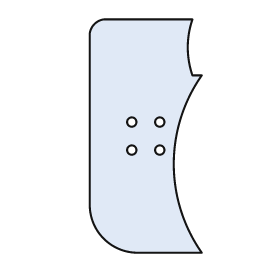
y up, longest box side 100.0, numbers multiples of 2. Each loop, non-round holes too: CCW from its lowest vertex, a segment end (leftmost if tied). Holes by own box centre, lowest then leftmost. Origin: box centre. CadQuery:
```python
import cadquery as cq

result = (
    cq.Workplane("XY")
    .moveTo(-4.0, -50.0)
    .lineTo(24.0, -50.0)
    .threePointArc((12.0, -12.0), (24.0, 26.0))
    .lineTo(20.0, 26.0)
    .threePointArc((18.0, 38.0), (20.0, 50.0))
    .lineTo(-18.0, 50.0)
    .threePointArc((-22.0, 48.0), (-24.0, 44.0))
    .lineTo(-24.0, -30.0)
    .threePointArc((-18.0, -44.0), (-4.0, -50.0))
    .close()
    .moveTo(-6.0, -6.0)
    .circle(2.0)
    .moveTo(6.0, -6.0)
    .circle(2.0)
    .moveTo(-6.0, 6.0)
    .circle(2.0)
    .moveTo(6.0, 6.0)
    .circle(2.0)
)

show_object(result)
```